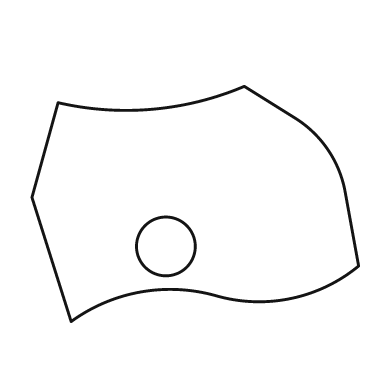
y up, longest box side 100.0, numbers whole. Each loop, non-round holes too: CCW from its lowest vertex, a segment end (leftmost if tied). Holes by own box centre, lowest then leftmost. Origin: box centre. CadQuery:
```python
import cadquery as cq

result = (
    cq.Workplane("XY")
    .moveTo(-38.0, -36.0)
    .threePointArc((-17.0, -27.0), (6.0, -28.0))
    .threePointArc((29.0, -29.0), (50.0, -19.0))
    .lineTo(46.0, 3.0)
    .threePointArc((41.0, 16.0), (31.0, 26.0))
    .lineTo(15.0, 36.0)
    .threePointArc((-13.0, 29.0), (-42.0, 31.0))
    .lineTo(-50.0, 2.0)
    .close()
    .moveTo(-9.0, -13.0)
    .circle(9.0)
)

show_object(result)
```